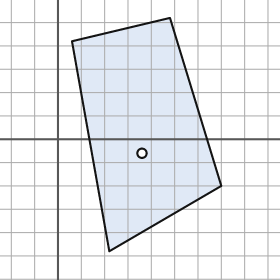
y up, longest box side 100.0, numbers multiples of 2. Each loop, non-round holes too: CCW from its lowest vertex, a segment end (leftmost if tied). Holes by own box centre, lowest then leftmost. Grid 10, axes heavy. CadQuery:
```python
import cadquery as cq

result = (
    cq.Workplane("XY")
    .moveTo(22.0, -48.0)
    .lineTo(70.0, -20.0)
    .lineTo(48.0, 52.0)
    .lineTo(6.0, 42.0)
    .close()
    .moveTo(36.0, -6.0)
    .circle(2.0)
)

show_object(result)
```